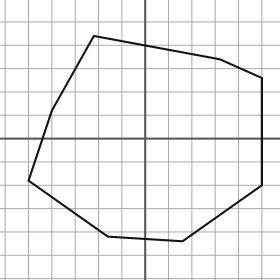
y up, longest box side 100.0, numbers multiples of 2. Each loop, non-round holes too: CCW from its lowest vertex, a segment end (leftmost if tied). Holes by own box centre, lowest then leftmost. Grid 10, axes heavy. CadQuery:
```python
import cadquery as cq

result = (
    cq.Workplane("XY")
    .moveTo(16.0, -44.0)
    .lineTo(50.0, -20.0)
    .lineTo(50.0, 26.0)
    .lineTo(32.0, 34.0)
    .lineTo(-22.0, 44.0)
    .lineTo(-40.0, 12.0)
    .lineTo(-50.0, -18.0)
    .lineTo(-16.0, -42.0)
    .close()
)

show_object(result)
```